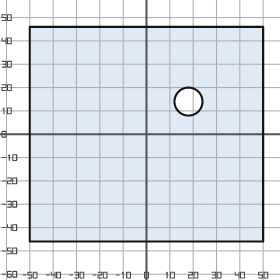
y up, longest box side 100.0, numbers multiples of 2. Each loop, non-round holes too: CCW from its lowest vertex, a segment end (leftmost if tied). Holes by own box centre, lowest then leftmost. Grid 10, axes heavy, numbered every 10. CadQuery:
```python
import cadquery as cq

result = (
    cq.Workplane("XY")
    .moveTo(-50.0, -46.0)
    .lineTo(50.0, -46.0)
    .lineTo(50.0, 46.0)
    .lineTo(-50.0, 46.0)
    .close()
    .moveTo(18.0, 14.0)
    .circle(6.0)
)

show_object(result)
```